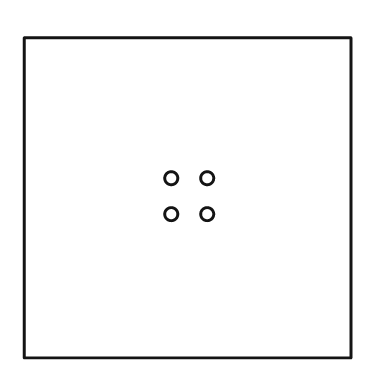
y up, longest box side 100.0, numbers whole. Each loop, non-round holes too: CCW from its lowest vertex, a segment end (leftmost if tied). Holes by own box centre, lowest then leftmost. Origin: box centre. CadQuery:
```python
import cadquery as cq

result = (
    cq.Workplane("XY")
    .moveTo(-50.0, -49.0)
    .lineTo(50.0, -49.0)
    .lineTo(50.0, 49.0)
    .lineTo(-50.0, 49.0)
    .close()
    .moveTo(-5.0, -5.0)
    .circle(2.0)
    .moveTo(6.0, -5.0)
    .circle(2.0)
    .moveTo(-5.0, 6.0)
    .circle(2.0)
    .moveTo(6.0, 6.0)
    .circle(2.0)
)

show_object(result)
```